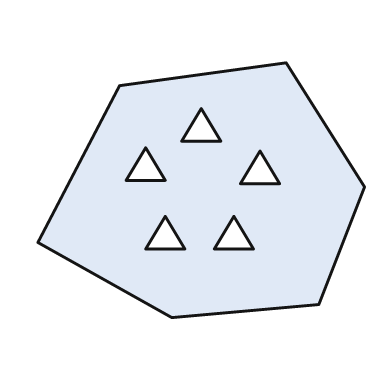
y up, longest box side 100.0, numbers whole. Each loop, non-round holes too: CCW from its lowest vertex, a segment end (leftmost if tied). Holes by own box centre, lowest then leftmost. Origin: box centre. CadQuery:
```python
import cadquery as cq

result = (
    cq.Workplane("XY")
    .moveTo(-9.0, -39.0)
    .lineTo(36.0, -35.0)
    .lineTo(50.0, 1.0)
    .lineTo(26.0, 39.0)
    .lineTo(-25.0, 32.0)
    .lineTo(-50.0, -16.0)
    .close()
    .moveTo(-17.0, -18.0)
    .lineTo(-5.0, -18.0)
    .lineTo(-11.0, -8.0)
    .close()
    .moveTo(4.0, -18.0)
    .lineTo(16.0, -18.0)
    .lineTo(10.0, -8.0)
    .close()
    .moveTo(12.0, 2.0)
    .lineTo(24.0, 2.0)
    .lineTo(18.0, 12.0)
    .close()
    .moveTo(-23.0, 3.0)
    .lineTo(-11.0, 3.0)
    .lineTo(-17.0, 13.0)
    .close()
    .moveTo(-6.0, 15.0)
    .lineTo(6.0, 15.0)
    .lineTo(0.0, 25.0)
    .close()
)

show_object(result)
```